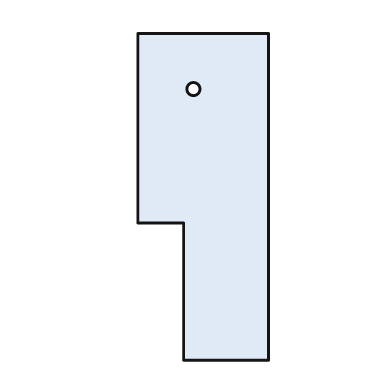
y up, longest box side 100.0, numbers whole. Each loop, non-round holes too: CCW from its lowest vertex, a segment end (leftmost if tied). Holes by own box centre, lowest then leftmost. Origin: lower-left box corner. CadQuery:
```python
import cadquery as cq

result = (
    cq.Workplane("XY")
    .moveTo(14.0, 0.0)
    .lineTo(40.0, 0.0)
    .lineTo(40.0, 100.0)
    .lineTo(0.0, 100.0)
    .lineTo(0.0, 42.0)
    .lineTo(14.0, 42.0)
    .close()
    .moveTo(17.0, 83.0)
    .circle(2.0)
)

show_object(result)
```